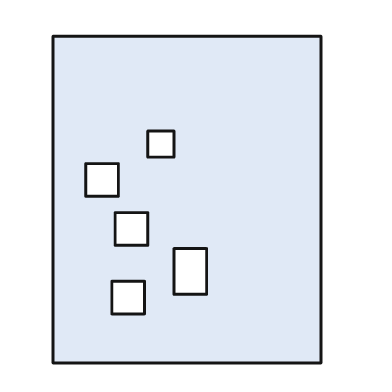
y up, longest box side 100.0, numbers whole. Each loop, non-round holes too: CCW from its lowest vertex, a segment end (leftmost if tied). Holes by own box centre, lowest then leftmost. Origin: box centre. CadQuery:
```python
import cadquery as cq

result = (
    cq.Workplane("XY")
    .moveTo(-41.0, -50.0)
    .lineTo(41.0, -50.0)
    .lineTo(41.0, 50.0)
    .lineTo(-41.0, 50.0)
    .close()
    .moveTo(-23.0, -35.0)
    .lineTo(-13.0, -35.0)
    .lineTo(-13.0, -25.0)
    .lineTo(-23.0, -25.0)
    .close()
    .moveTo(-4.0, -29.0)
    .lineTo(6.0, -29.0)
    .lineTo(6.0, -15.0)
    .lineTo(-4.0, -15.0)
    .close()
    .moveTo(-22.0, -14.0)
    .lineTo(-12.0, -14.0)
    .lineTo(-12.0, -4.0)
    .lineTo(-22.0, -4.0)
    .close()
    .moveTo(-31.0, 1.0)
    .lineTo(-21.0, 1.0)
    .lineTo(-21.0, 11.0)
    .lineTo(-31.0, 11.0)
    .close()
    .moveTo(-12.0, 13.0)
    .lineTo(-4.0, 13.0)
    .lineTo(-4.0, 21.0)
    .lineTo(-12.0, 21.0)
    .close()
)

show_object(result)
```